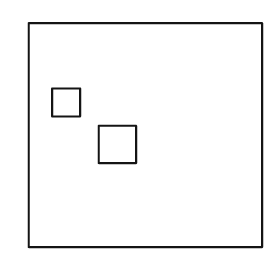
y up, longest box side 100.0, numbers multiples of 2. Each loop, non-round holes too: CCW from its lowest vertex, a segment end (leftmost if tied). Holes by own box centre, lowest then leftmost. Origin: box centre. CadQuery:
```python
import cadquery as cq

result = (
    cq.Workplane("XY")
    .moveTo(-50.0, -48.0)
    .lineTo(50.0, -48.0)
    .lineTo(50.0, 48.0)
    .lineTo(-50.0, 48.0)
    .close()
    .moveTo(-20.0, -12.0)
    .lineTo(-4.0, -12.0)
    .lineTo(-4.0, 4.0)
    .lineTo(-20.0, 4.0)
    .close()
    .moveTo(-40.0, 8.0)
    .lineTo(-28.0, 8.0)
    .lineTo(-28.0, 20.0)
    .lineTo(-40.0, 20.0)
    .close()
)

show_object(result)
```